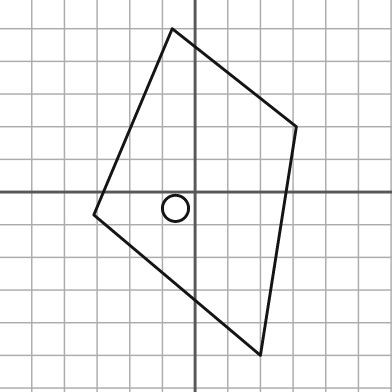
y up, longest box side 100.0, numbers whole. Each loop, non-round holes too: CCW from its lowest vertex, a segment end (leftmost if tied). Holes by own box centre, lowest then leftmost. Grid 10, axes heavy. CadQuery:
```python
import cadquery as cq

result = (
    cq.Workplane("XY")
    .moveTo(20.0, -50.0)
    .lineTo(31.0, 20.0)
    .lineTo(-7.0, 50.0)
    .lineTo(-31.0, -7.0)
    .close()
    .moveTo(-6.0, -5.0)
    .circle(4.0)
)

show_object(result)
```